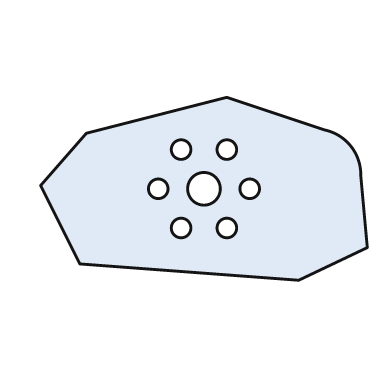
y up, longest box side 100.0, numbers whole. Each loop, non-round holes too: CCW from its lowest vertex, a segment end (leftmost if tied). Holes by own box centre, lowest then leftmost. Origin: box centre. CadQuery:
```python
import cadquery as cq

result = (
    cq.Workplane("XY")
    .moveTo(29.0, -28.0)
    .lineTo(50.0, -18.0)
    .lineTo(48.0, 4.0)
    .threePointArc((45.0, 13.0), (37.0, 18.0))
    .lineTo(7.0, 28.0)
    .lineTo(-36.0, 17.0)
    .lineTo(-50.0, 1.0)
    .lineTo(-38.0, -23.0)
    .close()
    .moveTo(-7.0, -12.0)
    .circle(3.0)
    .moveTo(7.0, -12.0)
    .circle(3.0)
    .moveTo(-14.0, 0.0)
    .circle(3.0)
    .moveTo(0.0, 0.0)
    .circle(5.0)
    .moveTo(14.0, 0.0)
    .circle(3.0)
    .moveTo(-7.0, 12.0)
    .circle(3.0)
    .moveTo(7.0, 12.0)
    .circle(3.0)
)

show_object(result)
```